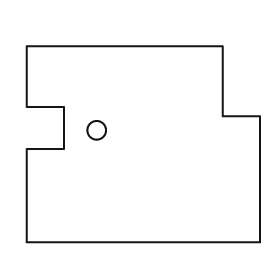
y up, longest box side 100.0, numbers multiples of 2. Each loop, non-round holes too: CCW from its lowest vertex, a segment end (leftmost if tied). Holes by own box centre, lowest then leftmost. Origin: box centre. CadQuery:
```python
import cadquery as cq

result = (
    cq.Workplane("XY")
    .moveTo(-50.0, -42.0)
    .lineTo(50.0, -42.0)
    .lineTo(50.0, 12.0)
    .lineTo(34.0, 12.0)
    .lineTo(34.0, 42.0)
    .lineTo(-50.0, 42.0)
    .lineTo(-50.0, 16.0)
    .lineTo(-34.0, 16.0)
    .lineTo(-34.0, -2.0)
    .lineTo(-50.0, -2.0)
    .close()
    .moveTo(-20.0, 6.0)
    .circle(4.0)
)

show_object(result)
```